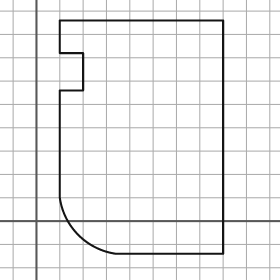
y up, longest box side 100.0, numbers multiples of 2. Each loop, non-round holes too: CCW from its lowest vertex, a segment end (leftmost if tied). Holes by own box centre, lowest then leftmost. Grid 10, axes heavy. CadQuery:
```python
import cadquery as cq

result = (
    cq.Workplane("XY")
    .moveTo(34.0, -14.0)
    .lineTo(80.0, -14.0)
    .lineTo(80.0, 86.0)
    .lineTo(10.0, 86.0)
    .lineTo(10.0, 72.0)
    .lineTo(20.0, 72.0)
    .lineTo(20.0, 56.0)
    .lineTo(10.0, 56.0)
    .lineTo(10.0, 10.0)
    .threePointArc((18.0, -6.0), (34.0, -14.0))
    .close()
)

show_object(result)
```